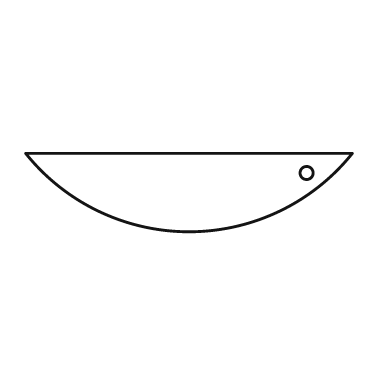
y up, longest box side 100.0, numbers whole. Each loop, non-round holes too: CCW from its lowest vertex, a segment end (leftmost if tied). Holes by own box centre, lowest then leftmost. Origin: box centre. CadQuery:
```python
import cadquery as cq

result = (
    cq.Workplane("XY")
    .moveTo(-50.0, 12.0)
    .threePointArc((0.0, -12.0), (50.0, 12.0))
    .close()
    .moveTo(36.0, 6.0)
    .circle(2.0)
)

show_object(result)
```